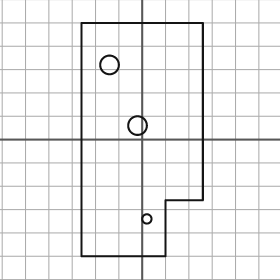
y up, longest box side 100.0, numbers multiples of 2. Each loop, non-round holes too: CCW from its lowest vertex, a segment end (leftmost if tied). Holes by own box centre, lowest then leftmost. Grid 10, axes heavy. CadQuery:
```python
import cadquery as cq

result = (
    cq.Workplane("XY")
    .moveTo(-26.0, -50.0)
    .lineTo(10.0, -50.0)
    .lineTo(10.0, -26.0)
    .lineTo(26.0, -26.0)
    .lineTo(26.0, 50.0)
    .lineTo(-26.0, 50.0)
    .close()
    .moveTo(2.0, -34.0)
    .circle(2.0)
    .moveTo(-2.0, 6.0)
    .circle(4.0)
    .moveTo(-14.0, 32.0)
    .circle(4.0)
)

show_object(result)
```